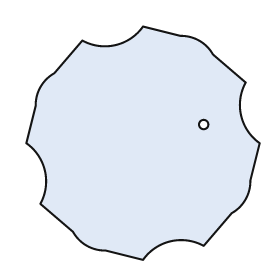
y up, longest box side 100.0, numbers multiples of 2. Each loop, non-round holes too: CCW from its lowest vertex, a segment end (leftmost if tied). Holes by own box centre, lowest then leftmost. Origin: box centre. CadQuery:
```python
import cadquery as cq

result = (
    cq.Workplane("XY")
    .moveTo(0.0, -50.0)
    .threePointArc((12.0, -42.0), (26.0, -44.0))
    .lineTo(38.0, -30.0)
    .threePointArc((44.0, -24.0), (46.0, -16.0))
    .lineTo(50.0, 0.0)
    .threePointArc((42.0, 12.0), (44.0, 26.0))
    .lineTo(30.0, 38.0)
    .threePointArc((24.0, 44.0), (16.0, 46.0))
    .lineTo(0.0, 50.0)
    .threePointArc((-12.0, 42.0), (-26.0, 44.0))
    .lineTo(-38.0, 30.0)
    .threePointArc((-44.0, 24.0), (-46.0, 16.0))
    .lineTo(-50.0, 0.0)
    .threePointArc((-42.0, -12.0), (-44.0, -26.0))
    .lineTo(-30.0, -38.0)
    .threePointArc((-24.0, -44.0), (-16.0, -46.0))
    .close()
    .moveTo(26.0, 8.0)
    .circle(2.0)
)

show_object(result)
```